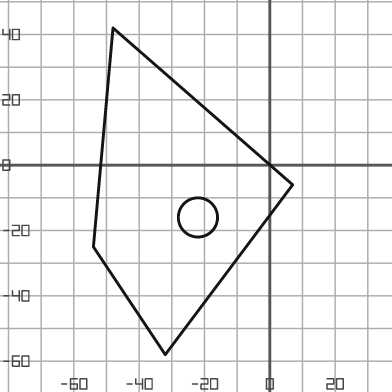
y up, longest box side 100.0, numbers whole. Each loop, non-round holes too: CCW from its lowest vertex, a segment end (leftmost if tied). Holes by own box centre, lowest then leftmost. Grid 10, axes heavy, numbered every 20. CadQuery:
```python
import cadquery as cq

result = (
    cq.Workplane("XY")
    .moveTo(-32.0, -58.0)
    .lineTo(7.0, -6.0)
    .lineTo(-48.0, 42.0)
    .lineTo(-54.0, -25.0)
    .close()
    .moveTo(-22.0, -16.0)
    .circle(6.0)
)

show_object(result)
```